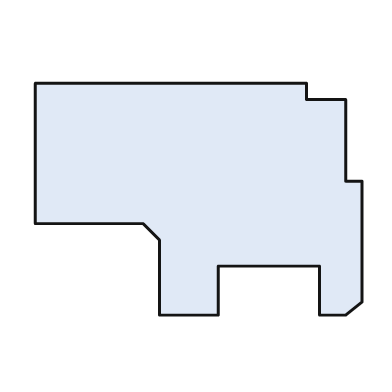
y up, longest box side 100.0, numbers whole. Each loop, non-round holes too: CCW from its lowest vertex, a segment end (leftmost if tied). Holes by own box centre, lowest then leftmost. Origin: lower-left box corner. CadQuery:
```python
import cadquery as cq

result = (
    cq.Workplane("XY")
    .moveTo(38.0, 0.0)
    .lineTo(56.0, 0.0)
    .lineTo(56.0, 15.0)
    .lineTo(87.0, 15.0)
    .lineTo(87.0, 0.0)
    .lineTo(95.0, 0.0)
    .lineTo(100.0, 4.0)
    .lineTo(100.0, 41.0)
    .lineTo(95.0, 41.0)
    .lineTo(95.0, 66.0)
    .lineTo(83.0, 66.0)
    .lineTo(83.0, 71.0)
    .lineTo(0.0, 71.0)
    .lineTo(0.0, 28.0)
    .lineTo(33.0, 28.0)
    .lineTo(38.0, 23.0)
    .close()
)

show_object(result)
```